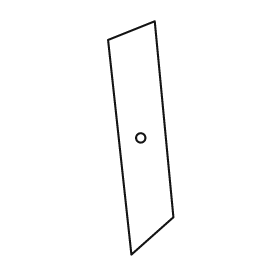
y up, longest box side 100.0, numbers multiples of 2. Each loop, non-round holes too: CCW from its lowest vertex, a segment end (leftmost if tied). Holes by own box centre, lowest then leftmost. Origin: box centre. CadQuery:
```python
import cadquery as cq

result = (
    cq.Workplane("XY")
    .moveTo(-4.0, -50.0)
    .lineTo(14.0, -34.0)
    .lineTo(6.0, 50.0)
    .lineTo(-14.0, 42.0)
    .close()
    .moveTo(0.0, 0.0)
    .circle(2.0)
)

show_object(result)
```